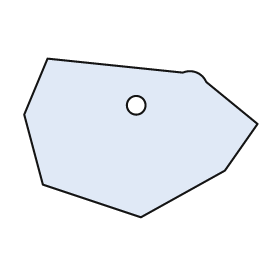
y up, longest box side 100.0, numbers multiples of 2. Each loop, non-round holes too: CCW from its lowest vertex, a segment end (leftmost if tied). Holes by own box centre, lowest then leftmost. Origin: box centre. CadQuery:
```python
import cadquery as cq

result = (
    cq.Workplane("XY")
    .moveTo(0.0, -34.0)
    .lineTo(36.0, -14.0)
    .lineTo(50.0, 6.0)
    .lineTo(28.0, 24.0)
    .threePointArc((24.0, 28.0), (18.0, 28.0))
    .lineTo(-40.0, 34.0)
    .lineTo(-50.0, 10.0)
    .lineTo(-42.0, -20.0)
    .close()
    .moveTo(-2.0, 14.0)
    .circle(4.0)
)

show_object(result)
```